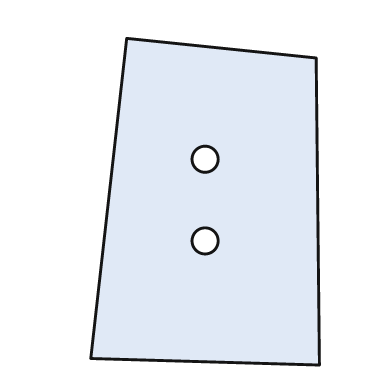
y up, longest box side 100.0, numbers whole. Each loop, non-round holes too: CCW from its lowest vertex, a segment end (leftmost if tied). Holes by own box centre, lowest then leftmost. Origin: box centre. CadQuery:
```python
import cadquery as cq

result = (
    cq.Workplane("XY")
    .moveTo(35.0, -50.0)
    .lineTo(34.0, 44.0)
    .lineTo(-24.0, 50.0)
    .lineTo(-35.0, -48.0)
    .close()
    .moveTo(0.0, -12.0)
    .circle(4.0)
    .moveTo(0.0, 13.0)
    .circle(4.0)
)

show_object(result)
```